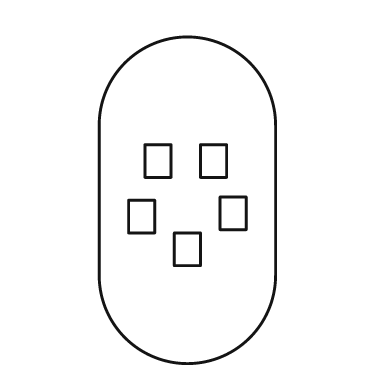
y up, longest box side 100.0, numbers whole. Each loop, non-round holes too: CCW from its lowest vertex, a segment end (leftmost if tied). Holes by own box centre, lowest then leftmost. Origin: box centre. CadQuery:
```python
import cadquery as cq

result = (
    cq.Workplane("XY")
    .moveTo(-27.0, -23.0)
    .threePointArc((0.0, -50.0), (27.0, -23.0))
    .lineTo(27.0, 23.0)
    .threePointArc((0.0, 50.0), (-27.0, 23.0))
    .close()
    .moveTo(-4.0, -20.0)
    .lineTo(4.0, -20.0)
    .lineTo(4.0, -10.0)
    .lineTo(-4.0, -10.0)
    .close()
    .moveTo(-18.0, -10.0)
    .lineTo(-10.0, -10.0)
    .lineTo(-10.0, 0.0)
    .lineTo(-18.0, 0.0)
    .close()
    .moveTo(10.0, -9.0)
    .lineTo(18.0, -9.0)
    .lineTo(18.0, 1.0)
    .lineTo(10.0, 1.0)
    .close()
    .moveTo(-13.0, 7.0)
    .lineTo(-5.0, 7.0)
    .lineTo(-5.0, 17.0)
    .lineTo(-13.0, 17.0)
    .close()
    .moveTo(4.0, 7.0)
    .lineTo(12.0, 7.0)
    .lineTo(12.0, 17.0)
    .lineTo(4.0, 17.0)
    .close()
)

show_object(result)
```